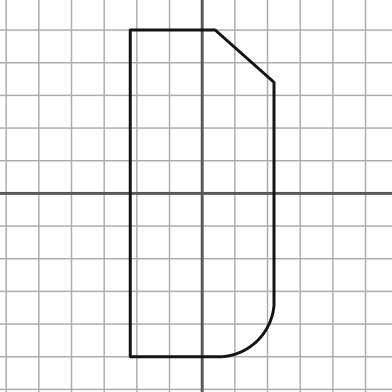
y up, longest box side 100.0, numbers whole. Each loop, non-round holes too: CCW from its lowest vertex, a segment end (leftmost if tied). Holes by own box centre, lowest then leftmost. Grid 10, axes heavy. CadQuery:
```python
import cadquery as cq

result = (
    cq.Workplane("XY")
    .moveTo(-22.0, -50.0)
    .lineTo(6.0, -50.0)
    .threePointArc((17.0, -45.0), (22.0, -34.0))
    .lineTo(22.0, 34.0)
    .lineTo(4.0, 50.0)
    .lineTo(-22.0, 50.0)
    .close()
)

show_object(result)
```